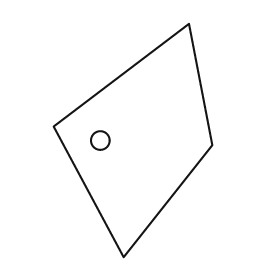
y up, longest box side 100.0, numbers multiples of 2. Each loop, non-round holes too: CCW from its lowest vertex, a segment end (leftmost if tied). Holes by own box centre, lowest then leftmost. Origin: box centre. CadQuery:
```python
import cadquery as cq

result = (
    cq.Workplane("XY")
    .moveTo(-4.0, -50.0)
    .lineTo(34.0, -2.0)
    .lineTo(24.0, 50.0)
    .lineTo(-34.0, 6.0)
    .close()
    .moveTo(-14.0, 0.0)
    .circle(4.0)
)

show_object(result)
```